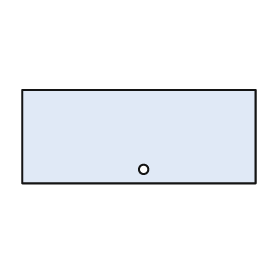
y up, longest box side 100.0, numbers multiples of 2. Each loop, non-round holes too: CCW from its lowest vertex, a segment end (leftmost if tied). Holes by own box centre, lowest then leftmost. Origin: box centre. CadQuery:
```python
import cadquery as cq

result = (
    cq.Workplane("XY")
    .moveTo(-50.0, -20.0)
    .lineTo(50.0, -20.0)
    .lineTo(50.0, 20.0)
    .lineTo(-50.0, 20.0)
    .close()
    .moveTo(2.0, -14.0)
    .circle(2.0)
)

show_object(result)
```